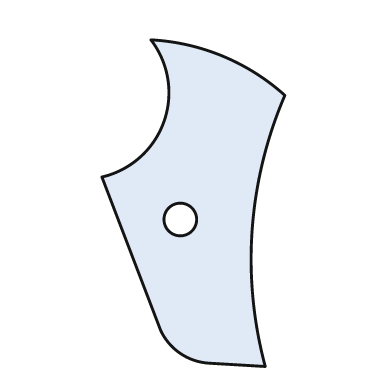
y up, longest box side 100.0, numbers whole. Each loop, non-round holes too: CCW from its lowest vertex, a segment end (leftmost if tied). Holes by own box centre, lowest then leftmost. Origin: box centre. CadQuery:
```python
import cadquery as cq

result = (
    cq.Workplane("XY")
    .moveTo(22.0, -50.0)
    .threePointArc((18.0, -8.0), (28.0, 33.0))
    .threePointArc((9.0, 45.0), (-13.0, 50.0))
    .threePointArc((-9.0, 25.0), (-28.0, 8.0))
    .lineTo(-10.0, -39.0)
    .threePointArc((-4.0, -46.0), (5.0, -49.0))
    .close()
    .moveTo(-4.0, -5.0)
    .circle(5.0)
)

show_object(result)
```